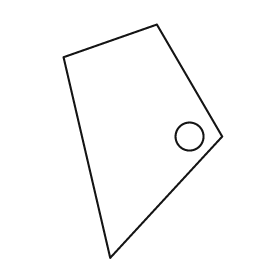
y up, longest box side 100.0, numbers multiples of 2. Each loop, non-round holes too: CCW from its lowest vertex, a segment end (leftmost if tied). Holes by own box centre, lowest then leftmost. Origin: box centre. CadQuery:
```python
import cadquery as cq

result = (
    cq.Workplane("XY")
    .moveTo(-14.0, -50.0)
    .lineTo(34.0, 2.0)
    .lineTo(6.0, 50.0)
    .lineTo(-34.0, 36.0)
    .close()
    .moveTo(20.0, 2.0)
    .circle(6.0)
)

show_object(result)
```